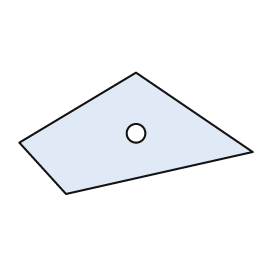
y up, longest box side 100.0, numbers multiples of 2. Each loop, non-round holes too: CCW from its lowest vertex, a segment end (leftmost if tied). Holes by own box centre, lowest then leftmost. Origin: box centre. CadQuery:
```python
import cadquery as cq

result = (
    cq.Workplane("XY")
    .moveTo(-30.0, -26.0)
    .lineTo(50.0, -8.0)
    .lineTo(0.0, 26.0)
    .lineTo(-50.0, -4.0)
    .close()
    .moveTo(0.0, 0.0)
    .circle(4.0)
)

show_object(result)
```